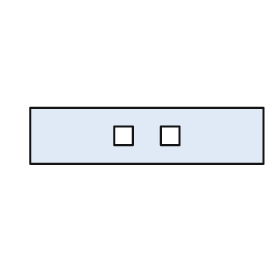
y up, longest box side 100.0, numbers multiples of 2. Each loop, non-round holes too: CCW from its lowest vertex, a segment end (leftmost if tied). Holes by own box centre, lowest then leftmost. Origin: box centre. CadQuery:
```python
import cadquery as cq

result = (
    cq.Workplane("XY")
    .moveTo(-50.0, -12.0)
    .lineTo(50.0, -12.0)
    .lineTo(50.0, 12.0)
    .lineTo(-50.0, 12.0)
    .close()
    .moveTo(-14.0, -4.0)
    .lineTo(-6.0, -4.0)
    .lineTo(-6.0, 4.0)
    .lineTo(-14.0, 4.0)
    .close()
    .moveTo(6.0, -4.0)
    .lineTo(14.0, -4.0)
    .lineTo(14.0, 4.0)
    .lineTo(6.0, 4.0)
    .close()
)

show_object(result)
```